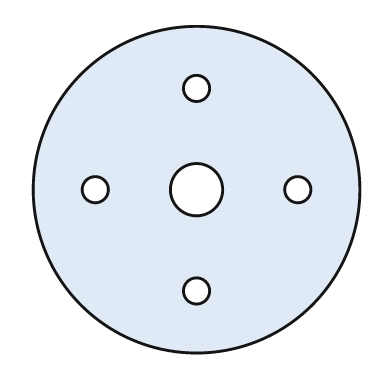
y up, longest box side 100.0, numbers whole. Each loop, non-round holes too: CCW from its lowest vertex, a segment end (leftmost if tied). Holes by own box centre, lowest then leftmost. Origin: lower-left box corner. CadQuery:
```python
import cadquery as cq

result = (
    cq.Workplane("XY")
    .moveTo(50.0, 50.0)
    .circle(50.0)
    .moveTo(50.0, 19.0)
    .circle(4.0)
    .moveTo(19.0, 50.0)
    .circle(4.0)
    .moveTo(50.0, 50.0)
    .circle(8.0)
    .moveTo(81.0, 50.0)
    .circle(4.0)
    .moveTo(50.0, 81.0)
    .circle(4.0)
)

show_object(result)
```